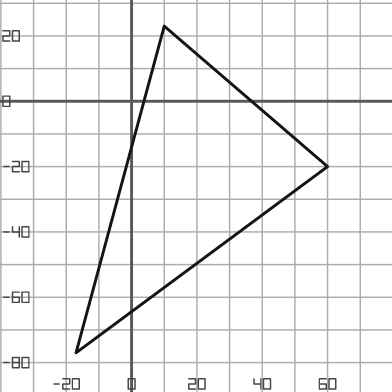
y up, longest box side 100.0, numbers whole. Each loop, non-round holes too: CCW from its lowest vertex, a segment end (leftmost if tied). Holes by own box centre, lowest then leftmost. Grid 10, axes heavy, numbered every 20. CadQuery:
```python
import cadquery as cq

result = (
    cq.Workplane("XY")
    .moveTo(-17.0, -77.0)
    .lineTo(60.0, -20.0)
    .lineTo(10.0, 23.0)
    .close()
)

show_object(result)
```